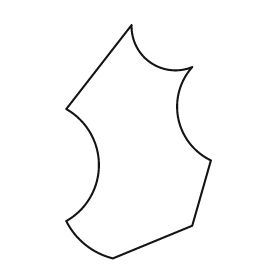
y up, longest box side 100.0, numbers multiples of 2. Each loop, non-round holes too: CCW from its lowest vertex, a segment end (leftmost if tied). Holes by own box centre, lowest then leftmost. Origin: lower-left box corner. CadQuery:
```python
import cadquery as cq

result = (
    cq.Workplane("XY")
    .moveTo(20.0, 0.0)
    .lineTo(54.0, 14.0)
    .lineTo(62.0, 42.0)
    .threePointArc((48.0, 60.0), (54.0, 82.0))
    .threePointArc((36.0, 84.0), (28.0, 100.0))
    .lineTo(0.0, 64.0)
    .threePointArc((14.0, 40.0), (0.0, 16.0))
    .threePointArc((8.0, 6.0), (20.0, 0.0))
    .close()
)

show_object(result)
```